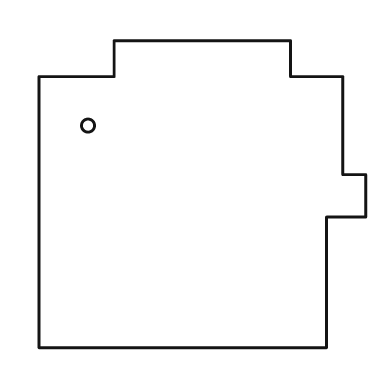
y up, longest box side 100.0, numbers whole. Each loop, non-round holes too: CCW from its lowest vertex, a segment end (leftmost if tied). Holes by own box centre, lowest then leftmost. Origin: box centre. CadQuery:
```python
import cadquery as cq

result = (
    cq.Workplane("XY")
    .moveTo(-50.0, -47.0)
    .lineTo(38.0, -47.0)
    .lineTo(38.0, -7.0)
    .lineTo(50.0, -7.0)
    .lineTo(50.0, 6.0)
    .lineTo(43.0, 6.0)
    .lineTo(43.0, 36.0)
    .lineTo(27.0, 36.0)
    .lineTo(27.0, 47.0)
    .lineTo(-27.0, 47.0)
    .lineTo(-27.0, 36.0)
    .lineTo(-50.0, 36.0)
    .close()
    .moveTo(-35.0, 21.0)
    .circle(2.0)
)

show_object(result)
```